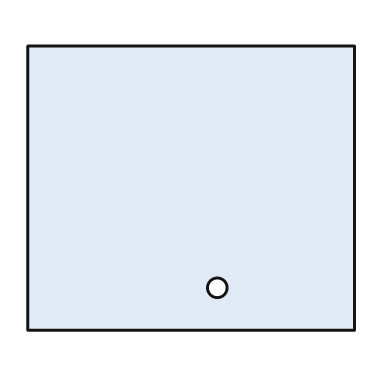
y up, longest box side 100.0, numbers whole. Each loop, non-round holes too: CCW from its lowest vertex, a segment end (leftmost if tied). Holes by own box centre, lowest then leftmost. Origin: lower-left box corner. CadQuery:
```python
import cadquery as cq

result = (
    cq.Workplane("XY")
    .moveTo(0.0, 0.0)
    .lineTo(100.0, 0.0)
    .lineTo(100.0, 87.0)
    .lineTo(0.0, 87.0)
    .close()
    .moveTo(58.0, 13.0)
    .circle(3.0)
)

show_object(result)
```